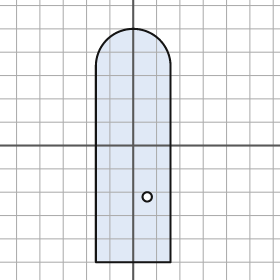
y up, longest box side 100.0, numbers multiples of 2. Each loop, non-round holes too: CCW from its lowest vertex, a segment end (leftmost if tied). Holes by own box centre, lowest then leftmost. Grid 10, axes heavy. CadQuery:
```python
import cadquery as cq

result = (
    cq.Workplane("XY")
    .moveTo(-16.0, -50.0)
    .lineTo(16.0, -50.0)
    .lineTo(16.0, 34.0)
    .threePointArc((0.0, 50.0), (-16.0, 34.0))
    .close()
    .moveTo(6.0, -22.0)
    .circle(2.0)
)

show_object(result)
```